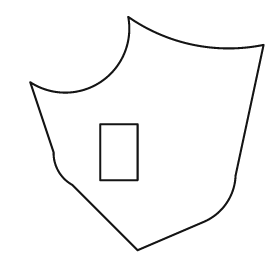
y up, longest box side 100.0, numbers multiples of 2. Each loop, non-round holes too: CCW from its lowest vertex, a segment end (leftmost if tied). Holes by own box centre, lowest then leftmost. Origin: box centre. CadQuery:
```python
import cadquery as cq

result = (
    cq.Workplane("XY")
    .moveTo(-4.0, -50.0)
    .lineTo(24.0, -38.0)
    .threePointArc((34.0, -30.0), (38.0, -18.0))
    .lineTo(50.0, 38.0)
    .threePointArc((20.0, 38.0), (-8.0, 50.0))
    .threePointArc((-20.0, 22.0), (-50.0, 22.0))
    .lineTo(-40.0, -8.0)
    .threePointArc((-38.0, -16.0), (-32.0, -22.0))
    .close()
    .moveTo(-20.0, -20.0)
    .lineTo(-4.0, -20.0)
    .lineTo(-4.0, 4.0)
    .lineTo(-20.0, 4.0)
    .close()
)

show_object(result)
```